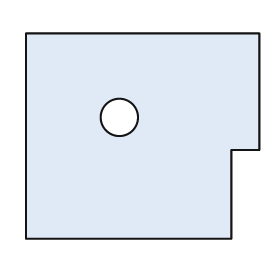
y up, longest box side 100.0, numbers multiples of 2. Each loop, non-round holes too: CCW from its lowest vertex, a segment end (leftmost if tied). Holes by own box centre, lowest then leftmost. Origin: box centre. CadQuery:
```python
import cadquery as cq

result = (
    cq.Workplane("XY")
    .moveTo(-50.0, -44.0)
    .lineTo(38.0, -44.0)
    .lineTo(38.0, -6.0)
    .lineTo(50.0, -6.0)
    .lineTo(50.0, 44.0)
    .lineTo(-50.0, 44.0)
    .close()
    .moveTo(-10.0, 8.0)
    .circle(8.0)
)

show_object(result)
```